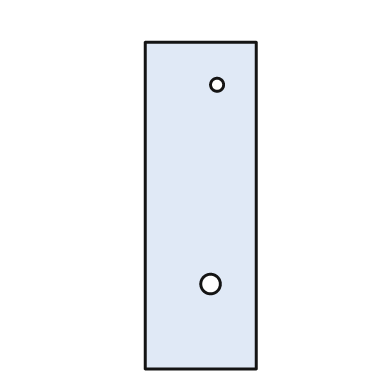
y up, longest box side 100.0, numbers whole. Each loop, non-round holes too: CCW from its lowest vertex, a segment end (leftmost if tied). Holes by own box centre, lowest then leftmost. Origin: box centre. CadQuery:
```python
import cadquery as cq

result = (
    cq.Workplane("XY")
    .moveTo(-17.0, -50.0)
    .lineTo(17.0, -50.0)
    .lineTo(17.0, 50.0)
    .lineTo(-17.0, 50.0)
    .close()
    .moveTo(3.0, -24.0)
    .circle(3.0)
    .moveTo(5.0, 37.0)
    .circle(2.0)
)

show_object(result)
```